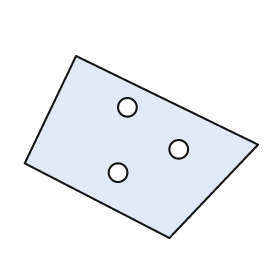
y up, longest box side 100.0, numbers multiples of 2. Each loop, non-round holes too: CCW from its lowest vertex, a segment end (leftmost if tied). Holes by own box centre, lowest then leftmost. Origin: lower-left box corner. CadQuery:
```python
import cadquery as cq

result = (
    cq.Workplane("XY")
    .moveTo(62.0, 0.0)
    .lineTo(100.0, 40.0)
    .lineTo(22.0, 78.0)
    .lineTo(0.0, 32.0)
    .close()
    .moveTo(40.0, 28.0)
    .circle(4.0)
    .moveTo(66.0, 38.0)
    .circle(4.0)
    .moveTo(44.0, 56.0)
    .circle(4.0)
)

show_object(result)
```